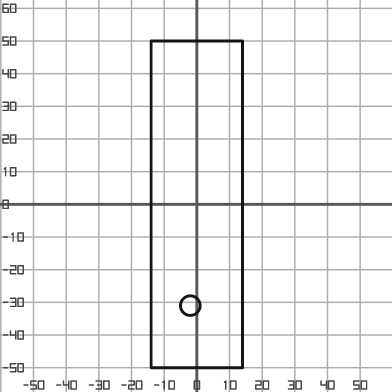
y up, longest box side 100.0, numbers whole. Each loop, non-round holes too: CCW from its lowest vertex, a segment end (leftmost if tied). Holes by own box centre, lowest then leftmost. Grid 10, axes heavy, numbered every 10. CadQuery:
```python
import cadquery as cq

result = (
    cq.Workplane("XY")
    .moveTo(-14.0, -50.0)
    .lineTo(14.0, -50.0)
    .lineTo(14.0, 50.0)
    .lineTo(-14.0, 50.0)
    .close()
    .moveTo(-2.0, -31.0)
    .circle(3.0)
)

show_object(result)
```